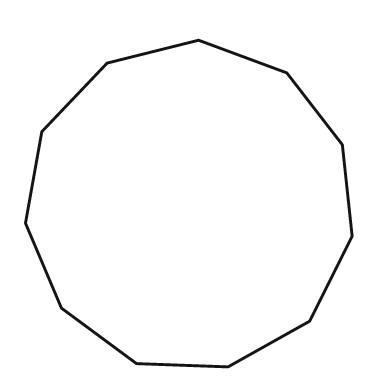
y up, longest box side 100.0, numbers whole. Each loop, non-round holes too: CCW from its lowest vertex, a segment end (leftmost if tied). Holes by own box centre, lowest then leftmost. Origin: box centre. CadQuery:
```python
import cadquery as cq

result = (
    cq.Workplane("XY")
    .moveTo(12.0, -50.0)
    .lineTo(37.0, -36.0)
    .lineTo(50.0, -10.0)
    .lineTo(47.0, 18.0)
    .lineTo(30.0, 40.0)
    .lineTo(3.0, 50.0)
    .lineTo(-25.0, 43.0)
    .lineTo(-45.0, 22.0)
    .lineTo(-50.0, -6.0)
    .lineTo(-39.0, -32.0)
    .lineTo(-16.0, -49.0)
    .close()
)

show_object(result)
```